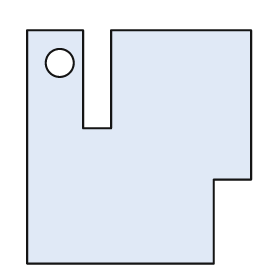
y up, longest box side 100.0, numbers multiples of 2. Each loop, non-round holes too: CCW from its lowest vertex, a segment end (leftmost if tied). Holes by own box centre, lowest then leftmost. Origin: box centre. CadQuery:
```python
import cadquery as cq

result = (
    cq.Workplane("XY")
    .moveTo(-48.0, -50.0)
    .lineTo(32.0, -50.0)
    .lineTo(32.0, -14.0)
    .lineTo(48.0, -14.0)
    .lineTo(48.0, 50.0)
    .lineTo(-12.0, 50.0)
    .lineTo(-12.0, 8.0)
    .lineTo(-24.0, 8.0)
    .lineTo(-24.0, 50.0)
    .lineTo(-48.0, 50.0)
    .close()
    .moveTo(-34.0, 36.0)
    .circle(6.0)
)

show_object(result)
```